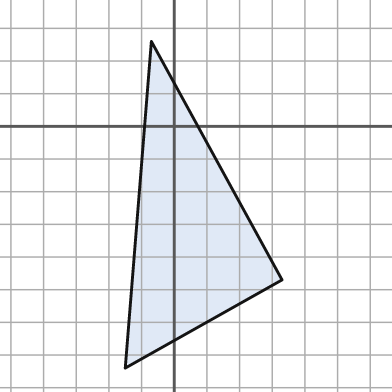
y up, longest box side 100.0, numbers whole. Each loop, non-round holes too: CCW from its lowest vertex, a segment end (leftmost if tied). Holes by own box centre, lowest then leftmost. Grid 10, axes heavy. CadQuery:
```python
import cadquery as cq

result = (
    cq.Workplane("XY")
    .moveTo(-15.0, -74.0)
    .lineTo(33.0, -47.0)
    .lineTo(-7.0, 26.0)
    .close()
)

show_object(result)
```